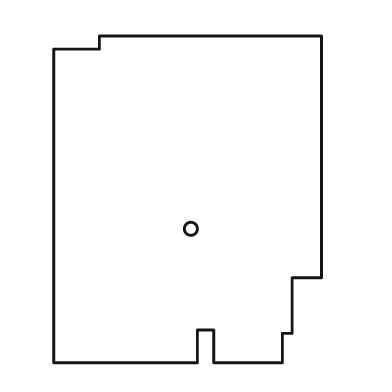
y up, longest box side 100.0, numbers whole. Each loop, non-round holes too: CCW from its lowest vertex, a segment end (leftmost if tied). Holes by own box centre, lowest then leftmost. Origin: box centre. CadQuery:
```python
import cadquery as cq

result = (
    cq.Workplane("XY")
    .moveTo(-41.0, -50.0)
    .lineTo(3.0, -50.0)
    .lineTo(3.0, -40.0)
    .lineTo(8.0, -40.0)
    .lineTo(8.0, -50.0)
    .lineTo(29.0, -50.0)
    .lineTo(29.0, -41.0)
    .lineTo(32.0, -41.0)
    .lineTo(32.0, -24.0)
    .lineTo(41.0, -24.0)
    .lineTo(41.0, 50.0)
    .lineTo(-27.0, 50.0)
    .lineTo(-27.0, 46.0)
    .lineTo(-41.0, 46.0)
    .close()
    .moveTo(1.0, -9.0)
    .circle(2.0)
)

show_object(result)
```